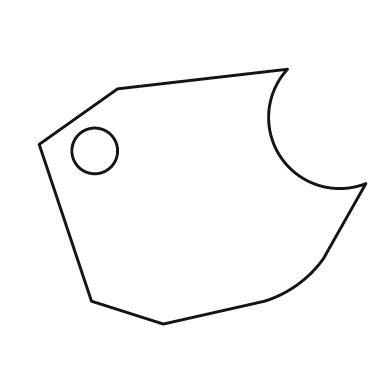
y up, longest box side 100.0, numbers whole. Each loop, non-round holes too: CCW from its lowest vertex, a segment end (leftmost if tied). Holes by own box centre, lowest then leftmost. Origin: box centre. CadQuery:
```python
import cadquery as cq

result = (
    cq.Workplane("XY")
    .moveTo(-12.0, -39.0)
    .lineTo(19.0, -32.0)
    .threePointArc((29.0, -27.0), (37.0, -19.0))
    .lineTo(50.0, 4.0)
    .threePointArc((24.0, 12.0), (26.0, 39.0))
    .lineTo(-26.0, 33.0)
    .lineTo(-50.0, 16.0)
    .lineTo(-34.0, -32.0)
    .close()
    .moveTo(-33.0, 14.0)
    .circle(7.0)
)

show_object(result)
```